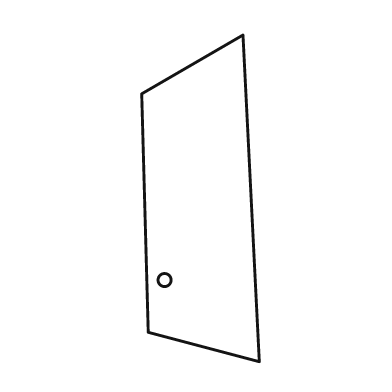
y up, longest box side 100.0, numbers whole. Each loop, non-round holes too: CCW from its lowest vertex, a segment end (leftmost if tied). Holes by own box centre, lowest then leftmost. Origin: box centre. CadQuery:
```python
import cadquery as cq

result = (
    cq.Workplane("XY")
    .moveTo(18.0, -50.0)
    .lineTo(13.0, 50.0)
    .lineTo(-18.0, 32.0)
    .lineTo(-16.0, -41.0)
    .close()
    .moveTo(-11.0, -25.0)
    .circle(2.0)
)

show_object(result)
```